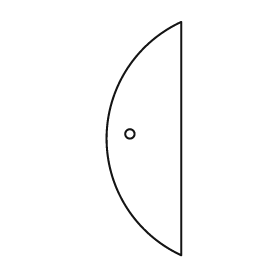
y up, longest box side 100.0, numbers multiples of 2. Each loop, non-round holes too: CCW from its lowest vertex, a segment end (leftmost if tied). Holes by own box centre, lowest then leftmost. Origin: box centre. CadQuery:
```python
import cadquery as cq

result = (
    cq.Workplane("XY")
    .moveTo(16.0, -50.0)
    .lineTo(16.0, 50.0)
    .threePointArc((-16.0, 0.0), (16.0, -50.0))
    .close()
    .moveTo(-6.0, 2.0)
    .circle(2.0)
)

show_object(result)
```